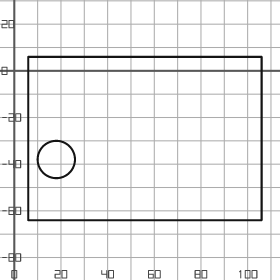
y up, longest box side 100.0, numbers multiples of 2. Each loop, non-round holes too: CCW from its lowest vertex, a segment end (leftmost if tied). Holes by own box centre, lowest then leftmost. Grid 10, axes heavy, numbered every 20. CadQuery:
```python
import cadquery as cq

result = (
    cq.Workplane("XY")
    .moveTo(6.0, -64.0)
    .lineTo(106.0, -64.0)
    .lineTo(106.0, 6.0)
    .lineTo(6.0, 6.0)
    .close()
    .moveTo(18.0, -38.0)
    .circle(8.0)
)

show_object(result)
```